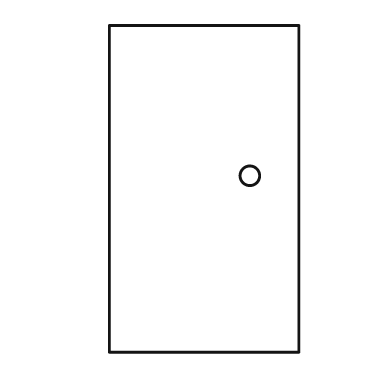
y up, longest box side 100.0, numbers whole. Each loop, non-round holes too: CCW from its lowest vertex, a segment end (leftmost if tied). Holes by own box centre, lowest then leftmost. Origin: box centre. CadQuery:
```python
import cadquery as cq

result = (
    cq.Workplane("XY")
    .moveTo(-29.0, -50.0)
    .lineTo(29.0, -50.0)
    .lineTo(29.0, 50.0)
    .lineTo(-29.0, 50.0)
    .close()
    .moveTo(14.0, 4.0)
    .circle(3.0)
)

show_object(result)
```